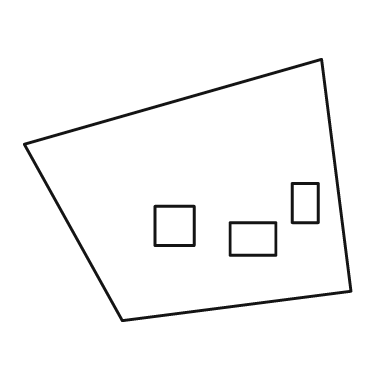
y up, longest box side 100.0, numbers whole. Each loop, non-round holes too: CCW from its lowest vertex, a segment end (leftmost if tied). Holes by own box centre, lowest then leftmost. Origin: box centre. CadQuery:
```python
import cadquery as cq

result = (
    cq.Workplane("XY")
    .moveTo(-20.0, -40.0)
    .lineTo(50.0, -31.0)
    .lineTo(41.0, 40.0)
    .lineTo(-50.0, 14.0)
    .close()
    .moveTo(13.0, -20.0)
    .lineTo(27.0, -20.0)
    .lineTo(27.0, -10.0)
    .lineTo(13.0, -10.0)
    .close()
    .moveTo(-10.0, -17.0)
    .lineTo(2.0, -17.0)
    .lineTo(2.0, -5.0)
    .lineTo(-10.0, -5.0)
    .close()
    .moveTo(32.0, -10.0)
    .lineTo(40.0, -10.0)
    .lineTo(40.0, 2.0)
    .lineTo(32.0, 2.0)
    .close()
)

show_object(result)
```